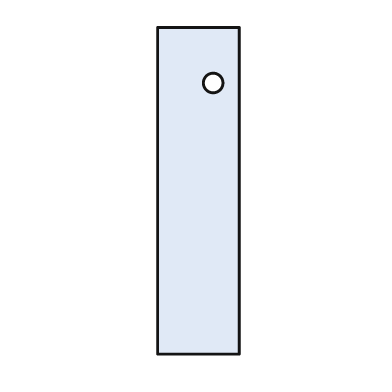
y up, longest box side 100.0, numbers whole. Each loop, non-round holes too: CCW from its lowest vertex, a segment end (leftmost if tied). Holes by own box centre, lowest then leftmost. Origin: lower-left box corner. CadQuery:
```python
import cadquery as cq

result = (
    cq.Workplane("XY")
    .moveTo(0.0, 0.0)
    .lineTo(25.0, 0.0)
    .lineTo(25.0, 100.0)
    .lineTo(0.0, 100.0)
    .close()
    .moveTo(17.0, 83.0)
    .circle(3.0)
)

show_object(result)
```